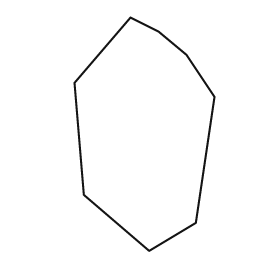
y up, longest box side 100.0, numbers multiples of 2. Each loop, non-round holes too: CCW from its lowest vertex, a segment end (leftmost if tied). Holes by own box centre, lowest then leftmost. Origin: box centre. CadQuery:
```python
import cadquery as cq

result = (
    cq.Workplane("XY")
    .moveTo(2.0, -50.0)
    .lineTo(22.0, -38.0)
    .lineTo(30.0, 16.0)
    .lineTo(18.0, 34.0)
    .lineTo(6.0, 44.0)
    .lineTo(-6.0, 50.0)
    .lineTo(-30.0, 22.0)
    .lineTo(-26.0, -26.0)
    .close()
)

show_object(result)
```